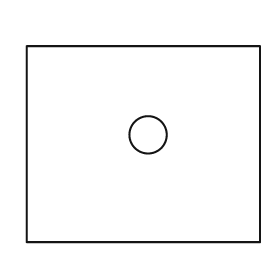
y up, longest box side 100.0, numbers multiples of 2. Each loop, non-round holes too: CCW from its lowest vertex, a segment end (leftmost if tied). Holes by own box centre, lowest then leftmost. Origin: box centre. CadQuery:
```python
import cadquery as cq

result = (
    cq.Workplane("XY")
    .moveTo(-50.0, -42.0)
    .lineTo(50.0, -42.0)
    .lineTo(50.0, 42.0)
    .lineTo(-50.0, 42.0)
    .close()
    .moveTo(2.0, 4.0)
    .circle(8.0)
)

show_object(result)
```